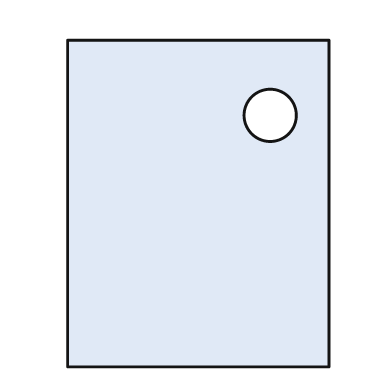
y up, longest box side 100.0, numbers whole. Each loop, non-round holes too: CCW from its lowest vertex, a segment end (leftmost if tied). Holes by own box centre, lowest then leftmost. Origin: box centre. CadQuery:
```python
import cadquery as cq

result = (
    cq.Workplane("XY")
    .moveTo(-40.0, -50.0)
    .lineTo(40.0, -50.0)
    .lineTo(40.0, 50.0)
    .lineTo(-40.0, 50.0)
    .close()
    .moveTo(22.0, 27.0)
    .circle(8.0)
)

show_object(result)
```